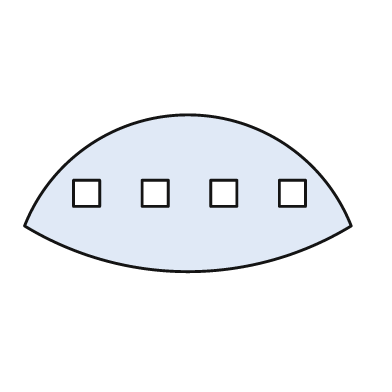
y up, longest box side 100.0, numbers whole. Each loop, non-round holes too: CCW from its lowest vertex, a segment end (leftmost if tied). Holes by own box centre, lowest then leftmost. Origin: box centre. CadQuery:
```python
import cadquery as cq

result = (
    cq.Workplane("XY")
    .moveTo(-50.0, -10.0)
    .threePointArc((0.0, -24.0), (50.0, -10.0))
    .threePointArc((0.0, 24.0), (-50.0, -10.0))
    .close()
    .moveTo(-35.0, -4.0)
    .lineTo(-27.0, -4.0)
    .lineTo(-27.0, 4.0)
    .lineTo(-35.0, 4.0)
    .close()
    .moveTo(-14.0, -4.0)
    .lineTo(-6.0, -4.0)
    .lineTo(-6.0, 4.0)
    .lineTo(-14.0, 4.0)
    .close()
    .moveTo(7.0, -4.0)
    .lineTo(15.0, -4.0)
    .lineTo(15.0, 4.0)
    .lineTo(7.0, 4.0)
    .close()
    .moveTo(28.0, -4.0)
    .lineTo(36.0, -4.0)
    .lineTo(36.0, 4.0)
    .lineTo(28.0, 4.0)
    .close()
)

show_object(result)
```